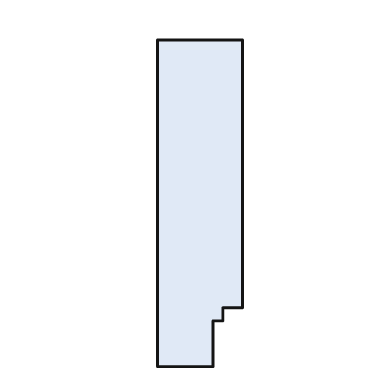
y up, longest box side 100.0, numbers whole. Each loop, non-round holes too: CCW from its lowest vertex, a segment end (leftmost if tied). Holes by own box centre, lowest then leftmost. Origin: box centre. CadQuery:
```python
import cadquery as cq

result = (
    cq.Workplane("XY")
    .moveTo(-13.0, -50.0)
    .lineTo(4.0, -50.0)
    .lineTo(4.0, -36.0)
    .lineTo(7.0, -36.0)
    .lineTo(7.0, -32.0)
    .lineTo(13.0, -32.0)
    .lineTo(13.0, 50.0)
    .lineTo(-13.0, 50.0)
    .close()
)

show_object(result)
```